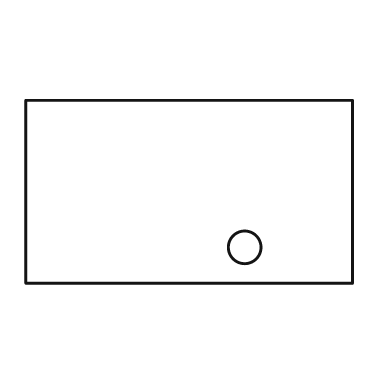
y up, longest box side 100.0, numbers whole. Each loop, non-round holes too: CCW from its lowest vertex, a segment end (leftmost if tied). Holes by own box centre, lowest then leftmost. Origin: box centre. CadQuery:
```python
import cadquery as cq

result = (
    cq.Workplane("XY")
    .moveTo(-50.0, -28.0)
    .lineTo(50.0, -28.0)
    .lineTo(50.0, 28.0)
    .lineTo(-50.0, 28.0)
    .close()
    .moveTo(17.0, -17.0)
    .circle(5.0)
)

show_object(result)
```